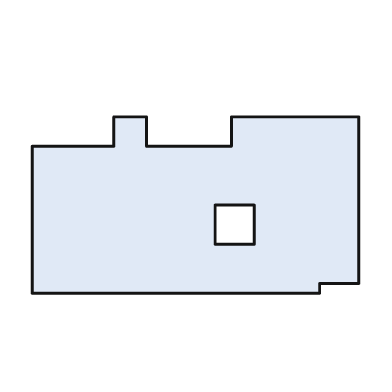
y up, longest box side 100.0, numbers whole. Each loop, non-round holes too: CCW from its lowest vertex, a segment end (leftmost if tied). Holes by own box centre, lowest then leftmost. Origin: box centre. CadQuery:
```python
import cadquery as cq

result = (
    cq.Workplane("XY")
    .moveTo(-50.0, -27.0)
    .lineTo(38.0, -27.0)
    .lineTo(38.0, -24.0)
    .lineTo(50.0, -24.0)
    .lineTo(50.0, 27.0)
    .lineTo(11.0, 27.0)
    .lineTo(11.0, 18.0)
    .lineTo(-15.0, 18.0)
    .lineTo(-15.0, 27.0)
    .lineTo(-25.0, 27.0)
    .lineTo(-25.0, 18.0)
    .lineTo(-50.0, 18.0)
    .close()
    .moveTo(6.0, -12.0)
    .lineTo(18.0, -12.0)
    .lineTo(18.0, 0.0)
    .lineTo(6.0, 0.0)
    .close()
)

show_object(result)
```